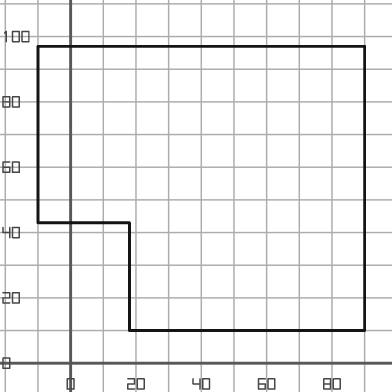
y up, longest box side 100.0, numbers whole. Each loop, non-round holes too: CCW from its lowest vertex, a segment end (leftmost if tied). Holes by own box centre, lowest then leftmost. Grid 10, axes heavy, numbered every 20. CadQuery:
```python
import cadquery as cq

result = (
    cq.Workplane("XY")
    .moveTo(18.0, 10.0)
    .lineTo(90.0, 10.0)
    .lineTo(90.0, 97.0)
    .lineTo(-10.0, 97.0)
    .lineTo(-10.0, 43.0)
    .lineTo(18.0, 43.0)
    .close()
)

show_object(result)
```